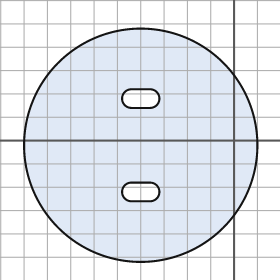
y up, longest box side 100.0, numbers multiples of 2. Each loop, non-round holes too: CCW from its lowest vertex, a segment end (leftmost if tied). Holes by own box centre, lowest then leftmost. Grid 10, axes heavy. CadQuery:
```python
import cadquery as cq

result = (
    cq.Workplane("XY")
    .moveTo(-40.0, -2.0)
    .circle(50.0)
    .moveTo(-44.0, -26.0)
    .lineTo(-36.0, -26.0)
    .threePointArc((-32.0, -22.0), (-36.0, -18.0))
    .lineTo(-44.0, -18.0)
    .threePointArc((-48.0, -22.0), (-44.0, -26.0))
    .close()
    .moveTo(-44.0, 14.0)
    .lineTo(-36.0, 14.0)
    .threePointArc((-32.0, 18.0), (-36.0, 22.0))
    .lineTo(-44.0, 22.0)
    .threePointArc((-48.0, 18.0), (-44.0, 14.0))
    .close()
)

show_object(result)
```